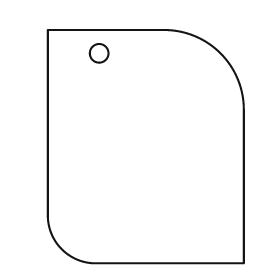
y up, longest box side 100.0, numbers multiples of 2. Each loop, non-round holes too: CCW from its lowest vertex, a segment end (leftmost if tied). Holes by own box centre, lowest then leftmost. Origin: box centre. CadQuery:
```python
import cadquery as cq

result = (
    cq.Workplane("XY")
    .moveTo(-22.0, -50.0)
    .lineTo(42.0, -50.0)
    .lineTo(42.0, 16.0)
    .threePointArc((32.0, 40.0), (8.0, 50.0))
    .lineTo(-42.0, 50.0)
    .lineTo(-42.0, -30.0)
    .threePointArc((-36.0, -44.0), (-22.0, -50.0))
    .close()
    .moveTo(-20.0, 40.0)
    .circle(4.0)
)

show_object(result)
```